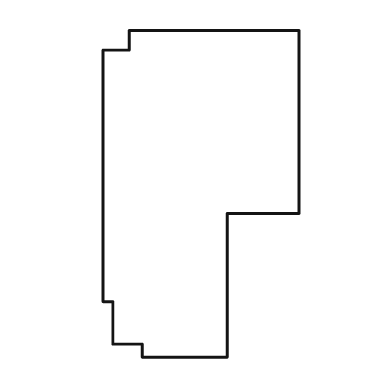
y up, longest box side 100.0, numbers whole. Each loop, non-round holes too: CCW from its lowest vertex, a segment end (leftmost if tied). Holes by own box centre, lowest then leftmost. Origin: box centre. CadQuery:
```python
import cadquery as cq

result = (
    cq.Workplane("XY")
    .moveTo(-18.0, -50.0)
    .lineTo(8.0, -50.0)
    .lineTo(8.0, -6.0)
    .lineTo(30.0, -6.0)
    .lineTo(30.0, 50.0)
    .lineTo(-22.0, 50.0)
    .lineTo(-22.0, 44.0)
    .lineTo(-30.0, 44.0)
    .lineTo(-30.0, -33.0)
    .lineTo(-27.0, -33.0)
    .lineTo(-27.0, -46.0)
    .lineTo(-18.0, -46.0)
    .close()
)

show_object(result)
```